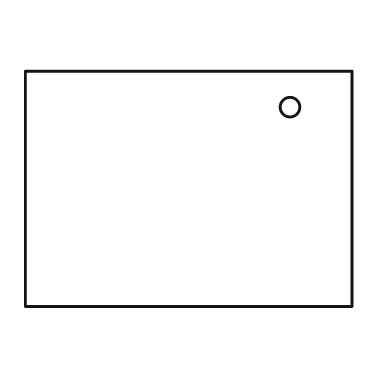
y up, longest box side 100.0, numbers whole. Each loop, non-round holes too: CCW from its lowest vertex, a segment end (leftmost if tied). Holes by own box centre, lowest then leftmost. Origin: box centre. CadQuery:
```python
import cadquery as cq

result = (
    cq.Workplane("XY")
    .moveTo(-50.0, -36.0)
    .lineTo(50.0, -36.0)
    .lineTo(50.0, 36.0)
    .lineTo(-50.0, 36.0)
    .close()
    .moveTo(31.0, 25.0)
    .circle(3.0)
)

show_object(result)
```